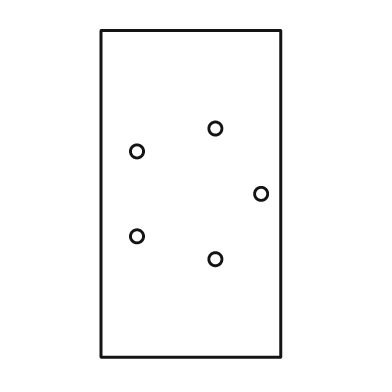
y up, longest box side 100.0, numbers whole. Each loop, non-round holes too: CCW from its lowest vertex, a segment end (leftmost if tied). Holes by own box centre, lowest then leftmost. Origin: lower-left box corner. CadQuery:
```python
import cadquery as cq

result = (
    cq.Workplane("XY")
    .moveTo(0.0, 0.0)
    .lineTo(55.0, 0.0)
    .lineTo(55.0, 100.0)
    .lineTo(0.0, 100.0)
    .close()
    .moveTo(35.0, 30.0)
    .circle(2.0)
    .moveTo(11.0, 37.0)
    .circle(2.0)
    .moveTo(49.0, 50.0)
    .circle(2.0)
    .moveTo(11.0, 63.0)
    .circle(2.0)
    .moveTo(35.0, 70.0)
    .circle(2.0)
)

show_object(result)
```